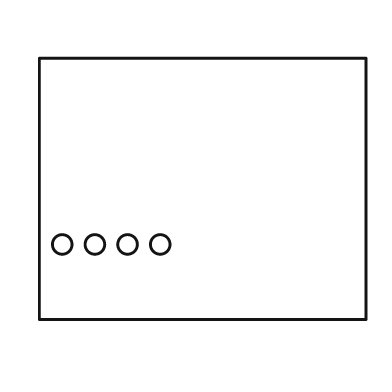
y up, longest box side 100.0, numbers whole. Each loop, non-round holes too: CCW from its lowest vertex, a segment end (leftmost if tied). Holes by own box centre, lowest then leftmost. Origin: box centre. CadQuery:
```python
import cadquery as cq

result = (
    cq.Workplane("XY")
    .moveTo(-50.0, -40.0)
    .lineTo(50.0, -40.0)
    .lineTo(50.0, 40.0)
    .lineTo(-50.0, 40.0)
    .close()
    .moveTo(-43.0, -17.0)
    .circle(3.0)
    .moveTo(-33.0, -17.0)
    .circle(3.0)
    .moveTo(-23.0, -17.0)
    .circle(3.0)
    .moveTo(-13.0, -17.0)
    .circle(3.0)
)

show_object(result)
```